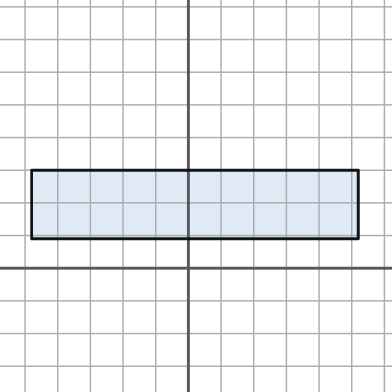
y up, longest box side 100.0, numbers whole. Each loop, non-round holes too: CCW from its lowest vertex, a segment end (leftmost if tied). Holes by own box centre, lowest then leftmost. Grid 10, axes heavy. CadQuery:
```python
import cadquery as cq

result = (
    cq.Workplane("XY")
    .moveTo(-48.0, 9.0)
    .lineTo(52.0, 9.0)
    .lineTo(52.0, 30.0)
    .lineTo(-48.0, 30.0)
    .close()
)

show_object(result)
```